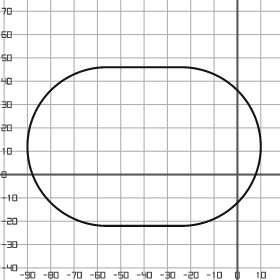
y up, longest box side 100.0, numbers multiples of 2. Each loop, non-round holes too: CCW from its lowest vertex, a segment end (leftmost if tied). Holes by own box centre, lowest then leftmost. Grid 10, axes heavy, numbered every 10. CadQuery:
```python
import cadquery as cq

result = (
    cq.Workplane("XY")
    .moveTo(-56.0, -22.0)
    .lineTo(-24.0, -22.0)
    .threePointArc((10.0, 12.0), (-24.0, 46.0))
    .lineTo(-56.0, 46.0)
    .threePointArc((-90.0, 12.0), (-56.0, -22.0))
    .close()
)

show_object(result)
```